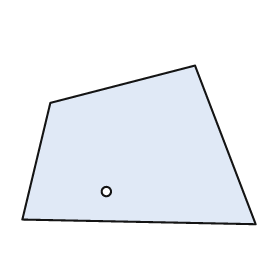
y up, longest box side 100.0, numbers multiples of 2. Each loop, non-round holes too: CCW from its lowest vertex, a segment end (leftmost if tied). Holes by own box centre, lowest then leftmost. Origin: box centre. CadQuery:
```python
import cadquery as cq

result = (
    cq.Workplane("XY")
    .moveTo(50.0, -34.0)
    .lineTo(24.0, 34.0)
    .lineTo(-38.0, 18.0)
    .lineTo(-50.0, -32.0)
    .close()
    .moveTo(-14.0, -20.0)
    .circle(2.0)
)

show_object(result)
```